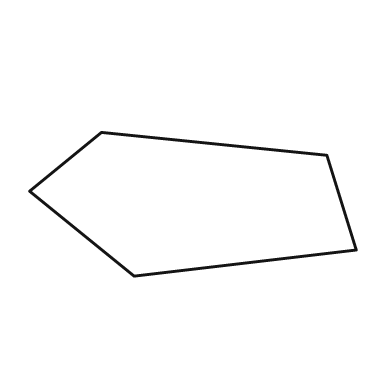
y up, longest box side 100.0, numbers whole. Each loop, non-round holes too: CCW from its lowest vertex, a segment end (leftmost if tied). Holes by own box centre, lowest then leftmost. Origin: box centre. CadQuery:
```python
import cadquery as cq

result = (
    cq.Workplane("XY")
    .moveTo(-18.0, -22.0)
    .lineTo(50.0, -14.0)
    .lineTo(41.0, 15.0)
    .lineTo(-28.0, 22.0)
    .lineTo(-50.0, 4.0)
    .close()
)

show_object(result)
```